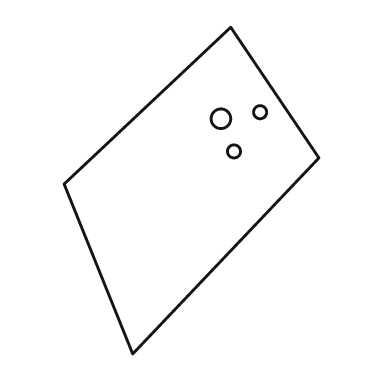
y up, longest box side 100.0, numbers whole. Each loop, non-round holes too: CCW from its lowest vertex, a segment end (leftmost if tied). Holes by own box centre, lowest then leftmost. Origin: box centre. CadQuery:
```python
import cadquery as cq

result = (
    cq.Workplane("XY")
    .moveTo(-18.0, -50.0)
    .lineTo(39.0, 10.0)
    .lineTo(12.0, 50.0)
    .lineTo(-39.0, 2.0)
    .close()
    .moveTo(13.0, 12.0)
    .circle(2.0)
    .moveTo(9.0, 22.0)
    .circle(3.0)
    .moveTo(21.0, 24.0)
    .circle(2.0)
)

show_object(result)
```